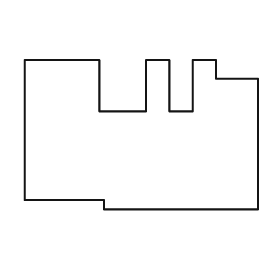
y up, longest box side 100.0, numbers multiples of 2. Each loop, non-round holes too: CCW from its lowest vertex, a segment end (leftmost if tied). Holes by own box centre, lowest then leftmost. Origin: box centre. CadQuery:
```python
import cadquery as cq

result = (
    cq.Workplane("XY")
    .moveTo(-16.0, -32.0)
    .lineTo(50.0, -32.0)
    .lineTo(50.0, 24.0)
    .lineTo(32.0, 24.0)
    .lineTo(32.0, 32.0)
    .lineTo(22.0, 32.0)
    .lineTo(22.0, 10.0)
    .lineTo(12.0, 10.0)
    .lineTo(12.0, 32.0)
    .lineTo(2.0, 32.0)
    .lineTo(2.0, 10.0)
    .lineTo(-18.0, 10.0)
    .lineTo(-18.0, 32.0)
    .lineTo(-50.0, 32.0)
    .lineTo(-50.0, -28.0)
    .lineTo(-16.0, -28.0)
    .close()
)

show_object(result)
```